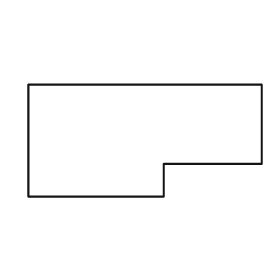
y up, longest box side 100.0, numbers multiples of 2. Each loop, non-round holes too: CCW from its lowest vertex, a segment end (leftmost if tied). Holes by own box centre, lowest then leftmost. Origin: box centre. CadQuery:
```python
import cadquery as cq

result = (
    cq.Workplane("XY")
    .moveTo(-50.0, -24.0)
    .lineTo(8.0, -24.0)
    .lineTo(8.0, -10.0)
    .lineTo(50.0, -10.0)
    .lineTo(50.0, 24.0)
    .lineTo(-50.0, 24.0)
    .close()
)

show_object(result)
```